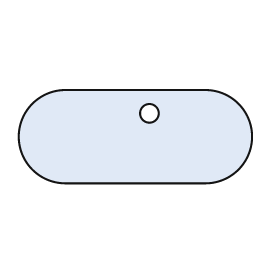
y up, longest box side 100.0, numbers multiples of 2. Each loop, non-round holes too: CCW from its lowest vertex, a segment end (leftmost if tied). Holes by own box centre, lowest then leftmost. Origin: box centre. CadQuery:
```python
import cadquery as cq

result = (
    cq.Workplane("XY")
    .moveTo(-30.0, -20.0)
    .lineTo(30.0, -20.0)
    .threePointArc((50.0, 0.0), (30.0, 20.0))
    .lineTo(-30.0, 20.0)
    .threePointArc((-50.0, 0.0), (-30.0, -20.0))
    .close()
    .moveTo(6.0, 10.0)
    .circle(4.0)
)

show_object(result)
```